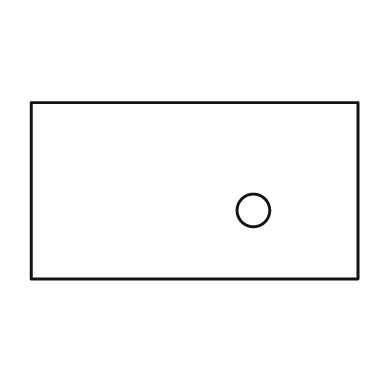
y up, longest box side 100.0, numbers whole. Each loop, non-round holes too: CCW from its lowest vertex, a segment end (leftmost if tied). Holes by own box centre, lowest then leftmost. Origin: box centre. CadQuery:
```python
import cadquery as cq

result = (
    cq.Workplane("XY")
    .moveTo(-50.0, -27.0)
    .lineTo(50.0, -27.0)
    .lineTo(50.0, 27.0)
    .lineTo(-50.0, 27.0)
    .close()
    .moveTo(18.0, -6.0)
    .circle(5.0)
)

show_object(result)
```